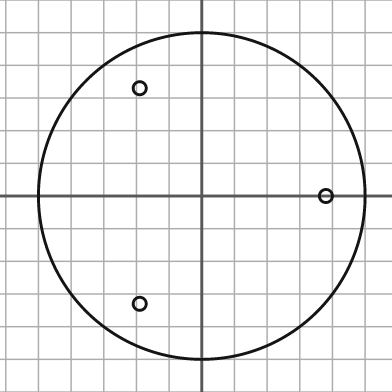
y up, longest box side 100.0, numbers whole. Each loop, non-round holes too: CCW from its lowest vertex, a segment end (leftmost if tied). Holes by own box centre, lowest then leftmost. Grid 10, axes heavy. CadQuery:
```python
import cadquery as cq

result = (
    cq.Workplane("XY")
    .moveTo(0.0, 0.0)
    .circle(50.0)
    .moveTo(-19.0, -33.0)
    .circle(2.0)
    .moveTo(38.0, 0.0)
    .circle(2.0)
    .moveTo(-19.0, 33.0)
    .circle(2.0)
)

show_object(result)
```